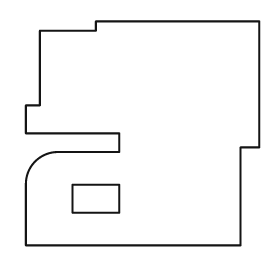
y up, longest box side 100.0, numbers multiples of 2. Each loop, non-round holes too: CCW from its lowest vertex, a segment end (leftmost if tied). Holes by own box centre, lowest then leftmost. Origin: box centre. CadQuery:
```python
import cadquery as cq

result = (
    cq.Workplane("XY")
    .moveTo(-50.0, -48.0)
    .lineTo(42.0, -48.0)
    .lineTo(42.0, -6.0)
    .lineTo(50.0, -6.0)
    .lineTo(50.0, 48.0)
    .lineTo(-20.0, 48.0)
    .lineTo(-20.0, 44.0)
    .lineTo(-44.0, 44.0)
    .lineTo(-44.0, 12.0)
    .lineTo(-50.0, 12.0)
    .lineTo(-50.0, 0.0)
    .lineTo(-10.0, 0.0)
    .lineTo(-10.0, -8.0)
    .lineTo(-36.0, -8.0)
    .threePointArc((-46.0, -12.0), (-50.0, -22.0))
    .close()
    .moveTo(-30.0, -34.0)
    .lineTo(-10.0, -34.0)
    .lineTo(-10.0, -22.0)
    .lineTo(-30.0, -22.0)
    .close()
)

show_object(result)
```